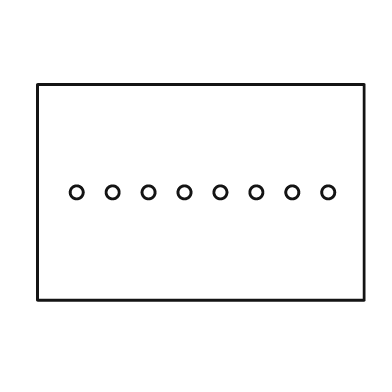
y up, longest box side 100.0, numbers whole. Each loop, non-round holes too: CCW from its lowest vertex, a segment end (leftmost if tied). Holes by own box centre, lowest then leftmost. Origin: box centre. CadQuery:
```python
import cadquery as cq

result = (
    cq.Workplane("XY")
    .moveTo(-50.0, -33.0)
    .lineTo(50.0, -33.0)
    .lineTo(50.0, 33.0)
    .lineTo(-50.0, 33.0)
    .close()
    .moveTo(-38.0, 0.0)
    .circle(2.0)
    .moveTo(-27.0, 0.0)
    .circle(2.0)
    .moveTo(-16.0, 0.0)
    .circle(2.0)
    .moveTo(-5.0, 0.0)
    .circle(2.0)
    .moveTo(6.0, 0.0)
    .circle(2.0)
    .moveTo(17.0, 0.0)
    .circle(2.0)
    .moveTo(28.0, 0.0)
    .circle(2.0)
    .moveTo(39.0, 0.0)
    .circle(2.0)
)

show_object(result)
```